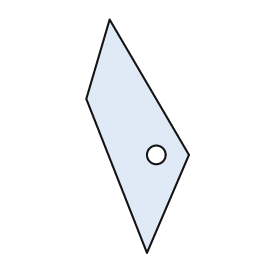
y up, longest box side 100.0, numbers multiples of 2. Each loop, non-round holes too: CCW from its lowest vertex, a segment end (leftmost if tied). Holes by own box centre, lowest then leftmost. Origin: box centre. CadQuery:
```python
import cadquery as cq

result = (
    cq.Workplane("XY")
    .moveTo(4.0, -50.0)
    .lineTo(22.0, -8.0)
    .lineTo(-12.0, 50.0)
    .lineTo(-22.0, 16.0)
    .close()
    .moveTo(8.0, -8.0)
    .circle(4.0)
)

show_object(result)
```